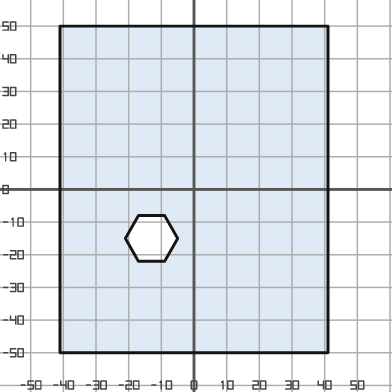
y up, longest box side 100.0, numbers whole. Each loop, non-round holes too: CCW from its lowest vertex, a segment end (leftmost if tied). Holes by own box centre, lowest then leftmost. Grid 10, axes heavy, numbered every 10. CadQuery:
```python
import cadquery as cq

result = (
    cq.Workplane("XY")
    .moveTo(-41.0, -50.0)
    .lineTo(41.0, -50.0)
    .lineTo(41.0, 50.0)
    .lineTo(-41.0, 50.0)
    .close()
    .moveTo(-17.0, -22.0)
    .lineTo(-9.0, -22.0)
    .lineTo(-5.0, -15.0)
    .lineTo(-9.0, -8.0)
    .lineTo(-17.0, -8.0)
    .lineTo(-21.0, -15.0)
    .close()
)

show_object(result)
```